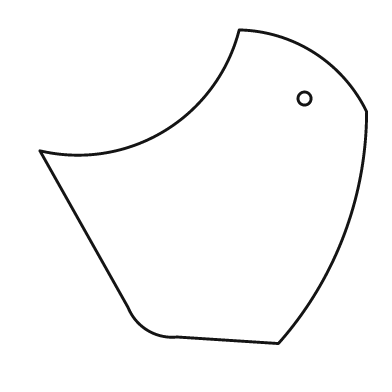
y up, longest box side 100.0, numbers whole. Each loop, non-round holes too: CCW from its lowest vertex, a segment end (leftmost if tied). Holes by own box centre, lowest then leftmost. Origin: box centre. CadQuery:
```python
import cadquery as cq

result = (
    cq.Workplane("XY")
    .moveTo(23.0, -48.0)
    .threePointArc((43.0, -15.0), (50.0, 23.0))
    .threePointArc((34.0, 41.0), (11.0, 48.0))
    .threePointArc((-12.0, 17.0), (-50.0, 11.0))
    .lineTo(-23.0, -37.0)
    .threePointArc((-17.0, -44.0), (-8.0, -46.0))
    .close()
    .moveTo(31.0, 27.0)
    .circle(2.0)
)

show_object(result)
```